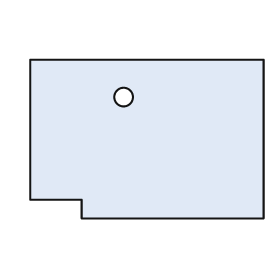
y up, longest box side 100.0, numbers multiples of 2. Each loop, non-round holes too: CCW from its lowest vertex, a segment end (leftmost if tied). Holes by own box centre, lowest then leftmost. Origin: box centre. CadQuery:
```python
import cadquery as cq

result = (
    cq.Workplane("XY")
    .moveTo(-28.0, -34.0)
    .lineTo(50.0, -34.0)
    .lineTo(50.0, 34.0)
    .lineTo(-50.0, 34.0)
    .lineTo(-50.0, -26.0)
    .lineTo(-28.0, -26.0)
    .close()
    .moveTo(-10.0, 18.0)
    .circle(4.0)
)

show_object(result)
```